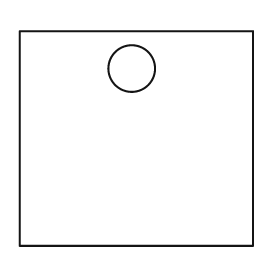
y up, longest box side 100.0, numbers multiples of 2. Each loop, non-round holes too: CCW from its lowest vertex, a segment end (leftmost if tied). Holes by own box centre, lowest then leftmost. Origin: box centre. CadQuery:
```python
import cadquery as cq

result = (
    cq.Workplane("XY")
    .moveTo(-50.0, -46.0)
    .lineTo(50.0, -46.0)
    .lineTo(50.0, 46.0)
    .lineTo(-50.0, 46.0)
    .close()
    .moveTo(-2.0, 30.0)
    .circle(10.0)
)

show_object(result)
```